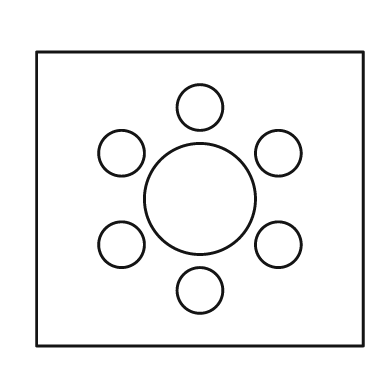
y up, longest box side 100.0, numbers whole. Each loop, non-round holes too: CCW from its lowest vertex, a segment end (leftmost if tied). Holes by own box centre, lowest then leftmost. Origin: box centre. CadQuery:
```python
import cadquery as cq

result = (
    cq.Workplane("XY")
    .moveTo(-50.0, -45.0)
    .lineTo(50.0, -45.0)
    .lineTo(50.0, 45.0)
    .lineTo(-50.0, 45.0)
    .close()
    .moveTo(0.0, -28.0)
    .circle(7.0)
    .moveTo(-24.0, -14.0)
    .circle(7.0)
    .moveTo(24.0, -14.0)
    .circle(7.0)
    .moveTo(0.0, 0.0)
    .circle(17.0)
    .moveTo(-24.0, 14.0)
    .circle(7.0)
    .moveTo(24.0, 14.0)
    .circle(7.0)
    .moveTo(0.0, 28.0)
    .circle(7.0)
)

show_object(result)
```